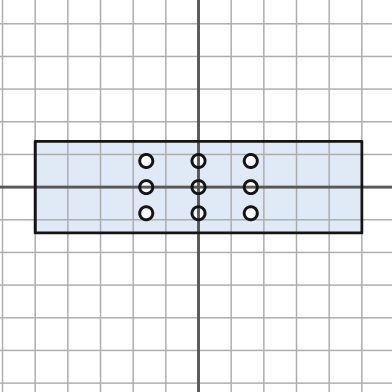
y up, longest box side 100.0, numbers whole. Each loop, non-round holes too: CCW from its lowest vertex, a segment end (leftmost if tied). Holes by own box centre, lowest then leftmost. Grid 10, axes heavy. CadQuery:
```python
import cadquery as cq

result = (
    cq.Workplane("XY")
    .moveTo(-50.0, -14.0)
    .lineTo(50.0, -14.0)
    .lineTo(50.0, 14.0)
    .lineTo(-50.0, 14.0)
    .close()
    .moveTo(-16.0, -8.0)
    .circle(2.0)
    .moveTo(0.0, -8.0)
    .circle(2.0)
    .moveTo(16.0, -8.0)
    .circle(2.0)
    .moveTo(-16.0, 0.0)
    .circle(2.0)
    .moveTo(0.0, 0.0)
    .circle(2.0)
    .moveTo(16.0, 0.0)
    .circle(2.0)
    .moveTo(-16.0, 8.0)
    .circle(2.0)
    .moveTo(0.0, 8.0)
    .circle(2.0)
    .moveTo(16.0, 8.0)
    .circle(2.0)
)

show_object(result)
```